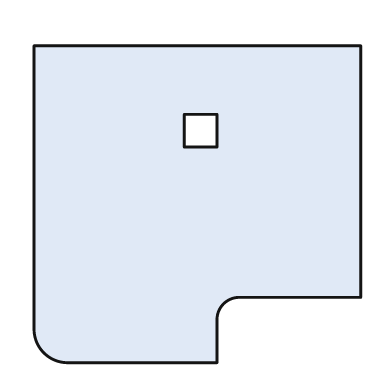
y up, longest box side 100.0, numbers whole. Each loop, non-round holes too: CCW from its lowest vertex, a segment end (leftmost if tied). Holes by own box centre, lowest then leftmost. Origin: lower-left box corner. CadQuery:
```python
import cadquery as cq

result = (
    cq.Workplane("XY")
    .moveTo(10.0, 0.0)
    .lineTo(56.0, 0.0)
    .lineTo(56.0, 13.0)
    .threePointArc((58.0, 18.0), (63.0, 20.0))
    .lineTo(100.0, 20.0)
    .lineTo(100.0, 97.0)
    .lineTo(0.0, 97.0)
    .lineTo(0.0, 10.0)
    .threePointArc((3.0, 3.0), (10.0, 0.0))
    .close()
    .moveTo(46.0, 66.0)
    .lineTo(56.0, 66.0)
    .lineTo(56.0, 76.0)
    .lineTo(46.0, 76.0)
    .close()
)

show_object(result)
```